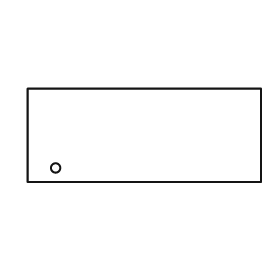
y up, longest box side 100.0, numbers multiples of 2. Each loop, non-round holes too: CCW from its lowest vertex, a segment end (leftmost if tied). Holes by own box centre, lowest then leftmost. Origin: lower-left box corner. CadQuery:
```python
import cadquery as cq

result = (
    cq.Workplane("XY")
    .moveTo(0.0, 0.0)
    .lineTo(100.0, 0.0)
    .lineTo(100.0, 40.0)
    .lineTo(0.0, 40.0)
    .close()
    .moveTo(12.0, 6.0)
    .circle(2.0)
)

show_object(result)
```